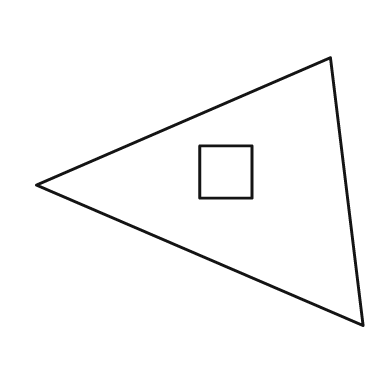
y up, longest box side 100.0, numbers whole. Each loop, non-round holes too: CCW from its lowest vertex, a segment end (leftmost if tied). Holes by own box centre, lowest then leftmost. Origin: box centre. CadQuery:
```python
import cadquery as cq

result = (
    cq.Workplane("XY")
    .moveTo(50.0, -41.0)
    .lineTo(40.0, 41.0)
    .lineTo(-50.0, 2.0)
    .close()
    .moveTo(0.0, -2.0)
    .lineTo(16.0, -2.0)
    .lineTo(16.0, 14.0)
    .lineTo(0.0, 14.0)
    .close()
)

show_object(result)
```